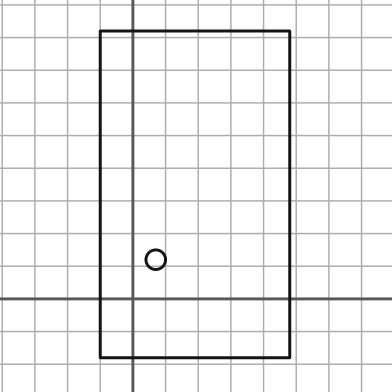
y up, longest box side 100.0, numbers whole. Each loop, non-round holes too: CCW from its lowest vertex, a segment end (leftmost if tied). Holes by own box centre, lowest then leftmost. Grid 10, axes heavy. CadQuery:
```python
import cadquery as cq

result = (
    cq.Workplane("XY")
    .moveTo(-10.0, -18.0)
    .lineTo(48.0, -18.0)
    .lineTo(48.0, 82.0)
    .lineTo(-10.0, 82.0)
    .close()
    .moveTo(7.0, 12.0)
    .circle(3.0)
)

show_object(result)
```